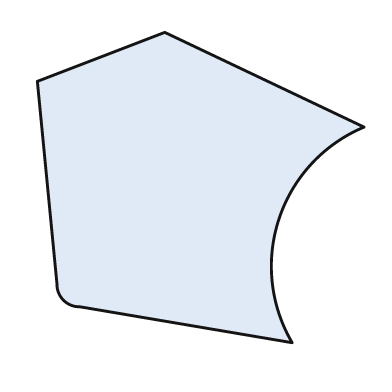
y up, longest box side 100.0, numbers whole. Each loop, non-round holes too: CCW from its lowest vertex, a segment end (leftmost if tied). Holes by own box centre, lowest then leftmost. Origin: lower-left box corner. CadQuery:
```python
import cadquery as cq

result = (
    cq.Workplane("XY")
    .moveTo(78.0, 0.0)
    .threePointArc((74.0, 38.0), (100.0, 66.0))
    .lineTo(39.0, 95.0)
    .lineTo(0.0, 80.0)
    .lineTo(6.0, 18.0)
    .threePointArc((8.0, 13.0), (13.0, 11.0))
    .close()
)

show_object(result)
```